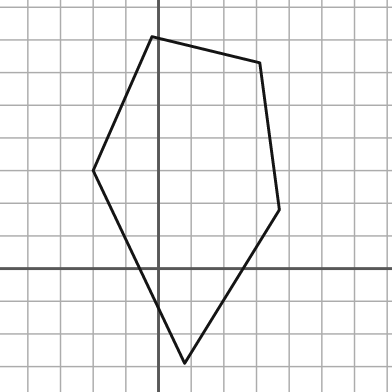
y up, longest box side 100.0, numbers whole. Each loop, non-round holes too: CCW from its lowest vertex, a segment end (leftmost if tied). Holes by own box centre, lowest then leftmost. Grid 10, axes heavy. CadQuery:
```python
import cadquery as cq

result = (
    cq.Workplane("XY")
    .moveTo(8.0, -29.0)
    .lineTo(37.0, 18.0)
    .lineTo(31.0, 63.0)
    .lineTo(-2.0, 71.0)
    .lineTo(-20.0, 30.0)
    .close()
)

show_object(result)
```